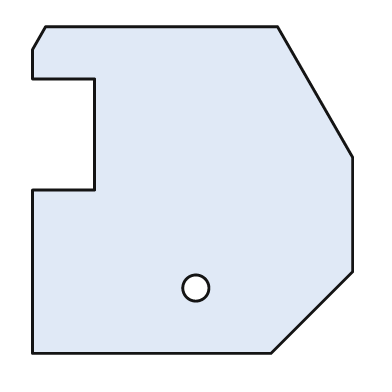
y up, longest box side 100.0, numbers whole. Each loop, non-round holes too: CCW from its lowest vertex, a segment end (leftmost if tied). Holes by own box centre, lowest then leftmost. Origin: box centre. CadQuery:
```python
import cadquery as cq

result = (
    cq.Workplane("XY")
    .moveTo(-49.0, -50.0)
    .lineTo(24.0, -50.0)
    .lineTo(49.0, -25.0)
    .lineTo(49.0, 10.0)
    .lineTo(26.0, 50.0)
    .lineTo(-45.0, 50.0)
    .lineTo(-49.0, 43.0)
    .lineTo(-49.0, 34.0)
    .lineTo(-30.0, 34.0)
    .lineTo(-30.0, 0.0)
    .lineTo(-49.0, 0.0)
    .close()
    .moveTo(1.0, -30.0)
    .circle(4.0)
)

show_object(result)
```